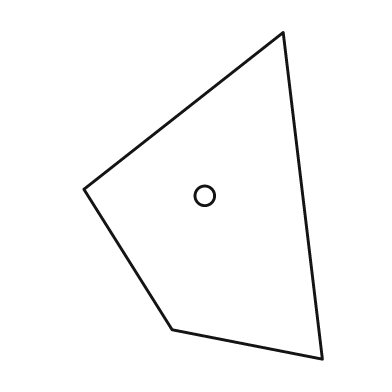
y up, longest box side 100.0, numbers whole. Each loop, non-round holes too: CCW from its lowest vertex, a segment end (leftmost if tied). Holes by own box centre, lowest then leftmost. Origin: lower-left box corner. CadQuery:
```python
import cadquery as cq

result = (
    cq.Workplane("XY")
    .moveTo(73.0, 0.0)
    .lineTo(61.0, 100.0)
    .lineTo(0.0, 52.0)
    .lineTo(27.0, 9.0)
    .close()
    .moveTo(37.0, 50.0)
    .circle(3.0)
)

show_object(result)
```